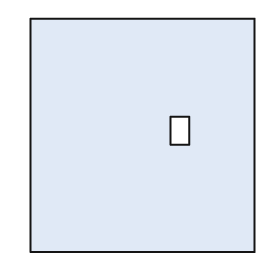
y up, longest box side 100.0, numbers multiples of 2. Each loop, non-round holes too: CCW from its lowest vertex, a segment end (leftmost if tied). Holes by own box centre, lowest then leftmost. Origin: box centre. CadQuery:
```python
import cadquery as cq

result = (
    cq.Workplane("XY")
    .moveTo(-48.0, -50.0)
    .lineTo(48.0, -50.0)
    .lineTo(48.0, 50.0)
    .lineTo(-48.0, 50.0)
    .close()
    .moveTo(12.0, -4.0)
    .lineTo(20.0, -4.0)
    .lineTo(20.0, 8.0)
    .lineTo(12.0, 8.0)
    .close()
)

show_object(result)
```